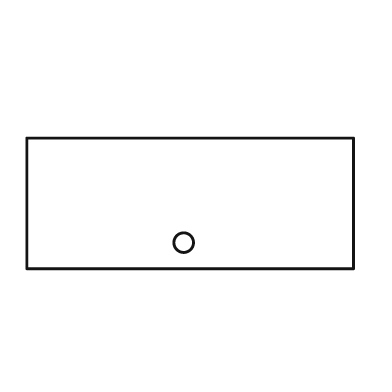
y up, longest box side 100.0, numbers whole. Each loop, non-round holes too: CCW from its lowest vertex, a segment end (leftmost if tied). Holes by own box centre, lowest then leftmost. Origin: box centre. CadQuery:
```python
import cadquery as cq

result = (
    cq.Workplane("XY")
    .moveTo(-50.0, -20.0)
    .lineTo(50.0, -20.0)
    .lineTo(50.0, 20.0)
    .lineTo(-50.0, 20.0)
    .close()
    .moveTo(-2.0, -12.0)
    .circle(3.0)
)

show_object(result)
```